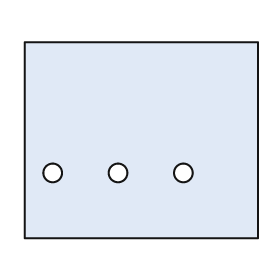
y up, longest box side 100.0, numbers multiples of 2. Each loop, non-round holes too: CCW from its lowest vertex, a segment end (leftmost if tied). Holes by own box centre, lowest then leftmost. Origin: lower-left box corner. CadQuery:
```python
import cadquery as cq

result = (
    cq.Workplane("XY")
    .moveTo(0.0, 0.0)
    .lineTo(100.0, 0.0)
    .lineTo(100.0, 84.0)
    .lineTo(0.0, 84.0)
    .close()
    .moveTo(12.0, 28.0)
    .circle(4.0)
    .moveTo(40.0, 28.0)
    .circle(4.0)
    .moveTo(68.0, 28.0)
    .circle(4.0)
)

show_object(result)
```